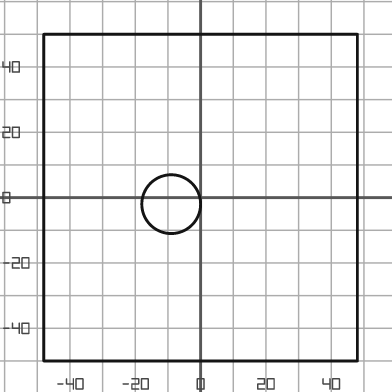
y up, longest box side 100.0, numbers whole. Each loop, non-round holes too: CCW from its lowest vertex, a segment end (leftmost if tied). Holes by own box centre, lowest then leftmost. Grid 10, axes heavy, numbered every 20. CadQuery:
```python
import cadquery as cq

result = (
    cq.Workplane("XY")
    .moveTo(-48.0, -50.0)
    .lineTo(48.0, -50.0)
    .lineTo(48.0, 50.0)
    .lineTo(-48.0, 50.0)
    .close()
    .moveTo(-9.0, -2.0)
    .circle(9.0)
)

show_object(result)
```